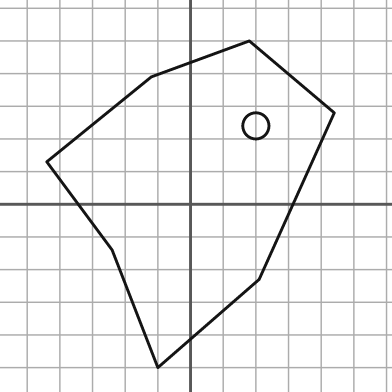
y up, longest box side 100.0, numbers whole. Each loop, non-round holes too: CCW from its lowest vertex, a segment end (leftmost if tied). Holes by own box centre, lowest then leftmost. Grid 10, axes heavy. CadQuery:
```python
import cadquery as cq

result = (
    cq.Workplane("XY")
    .moveTo(-10.0, -50.0)
    .lineTo(21.0, -23.0)
    .lineTo(44.0, 28.0)
    .lineTo(18.0, 50.0)
    .lineTo(-12.0, 39.0)
    .lineTo(-44.0, 13.0)
    .lineTo(-24.0, -14.0)
    .close()
    .moveTo(20.0, 24.0)
    .circle(4.0)
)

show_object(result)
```